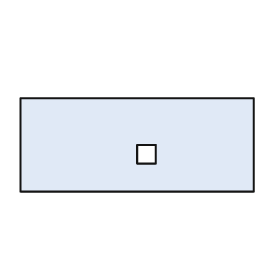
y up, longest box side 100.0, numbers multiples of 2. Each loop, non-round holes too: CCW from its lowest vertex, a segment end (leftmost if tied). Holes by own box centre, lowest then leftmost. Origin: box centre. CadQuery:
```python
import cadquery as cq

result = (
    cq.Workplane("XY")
    .moveTo(-50.0, -20.0)
    .lineTo(50.0, -20.0)
    .lineTo(50.0, 20.0)
    .lineTo(-50.0, 20.0)
    .close()
    .moveTo(0.0, -8.0)
    .lineTo(8.0, -8.0)
    .lineTo(8.0, 0.0)
    .lineTo(0.0, 0.0)
    .close()
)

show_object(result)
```